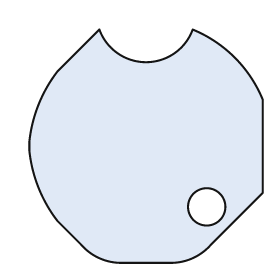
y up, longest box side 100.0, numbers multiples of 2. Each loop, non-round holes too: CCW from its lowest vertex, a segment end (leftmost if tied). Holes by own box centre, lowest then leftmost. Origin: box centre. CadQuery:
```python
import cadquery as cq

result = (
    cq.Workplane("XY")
    .moveTo(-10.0, -50.0)
    .lineTo(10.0, -50.0)
    .threePointArc((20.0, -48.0), (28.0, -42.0))
    .lineTo(50.0, -20.0)
    .lineTo(50.0, 20.0)
    .threePointArc((38.0, 38.0), (20.0, 50.0))
    .threePointArc((0.0, 36.0), (-20.0, 50.0))
    .lineTo(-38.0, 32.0)
    .threePointArc((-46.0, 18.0), (-50.0, 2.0))
    .lineTo(-50.0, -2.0)
    .threePointArc((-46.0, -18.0), (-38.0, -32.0))
    .lineTo(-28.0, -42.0)
    .threePointArc((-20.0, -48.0), (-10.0, -50.0))
    .close()
    .moveTo(26.0, -26.0)
    .circle(8.0)
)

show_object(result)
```